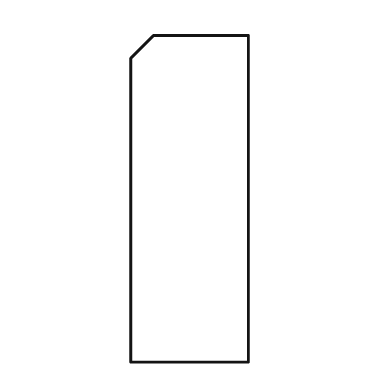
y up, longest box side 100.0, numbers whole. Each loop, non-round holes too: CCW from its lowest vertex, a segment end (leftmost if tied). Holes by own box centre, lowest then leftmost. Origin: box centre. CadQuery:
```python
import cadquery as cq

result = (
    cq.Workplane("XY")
    .moveTo(-18.0, -50.0)
    .lineTo(18.0, -50.0)
    .lineTo(18.0, 50.0)
    .lineTo(-11.0, 50.0)
    .lineTo(-18.0, 43.0)
    .close()
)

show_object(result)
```